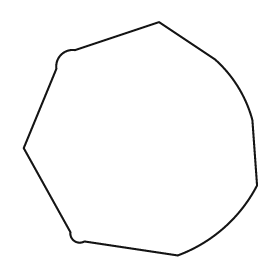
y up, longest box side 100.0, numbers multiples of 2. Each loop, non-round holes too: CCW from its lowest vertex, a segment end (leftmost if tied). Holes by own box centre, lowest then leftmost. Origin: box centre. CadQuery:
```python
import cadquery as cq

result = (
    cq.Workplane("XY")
    .moveTo(16.0, -50.0)
    .threePointArc((36.0, -38.0), (50.0, -20.0))
    .lineTo(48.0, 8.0)
    .threePointArc((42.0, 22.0), (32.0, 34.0))
    .lineTo(8.0, 50.0)
    .lineTo(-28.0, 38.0)
    .threePointArc((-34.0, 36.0), (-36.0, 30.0))
    .lineTo(-50.0, -4.0)
    .lineTo(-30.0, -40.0)
    .threePointArc((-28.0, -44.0), (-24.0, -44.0))
    .close()
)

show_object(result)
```